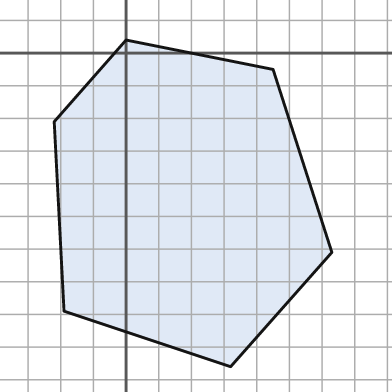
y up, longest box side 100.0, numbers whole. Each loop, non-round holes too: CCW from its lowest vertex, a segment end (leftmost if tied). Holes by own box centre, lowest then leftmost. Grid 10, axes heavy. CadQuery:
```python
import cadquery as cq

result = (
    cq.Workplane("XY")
    .moveTo(32.0, -96.0)
    .lineTo(63.0, -61.0)
    .lineTo(45.0, -5.0)
    .lineTo(0.0, 4.0)
    .lineTo(-22.0, -21.0)
    .lineTo(-19.0, -79.0)
    .close()
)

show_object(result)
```